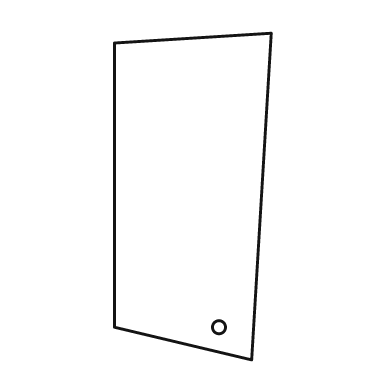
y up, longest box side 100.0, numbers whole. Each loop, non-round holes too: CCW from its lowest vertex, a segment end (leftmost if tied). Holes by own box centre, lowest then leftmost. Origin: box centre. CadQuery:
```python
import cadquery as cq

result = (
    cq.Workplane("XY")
    .moveTo(18.0, -50.0)
    .lineTo(24.0, 50.0)
    .lineTo(-24.0, 47.0)
    .lineTo(-24.0, -40.0)
    .close()
    .moveTo(8.0, -40.0)
    .circle(2.0)
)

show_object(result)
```